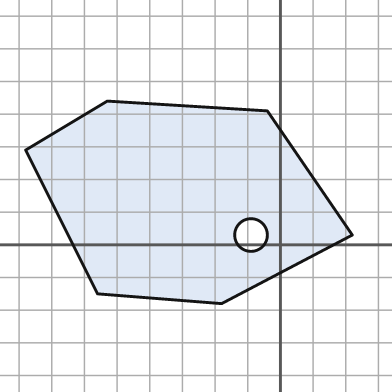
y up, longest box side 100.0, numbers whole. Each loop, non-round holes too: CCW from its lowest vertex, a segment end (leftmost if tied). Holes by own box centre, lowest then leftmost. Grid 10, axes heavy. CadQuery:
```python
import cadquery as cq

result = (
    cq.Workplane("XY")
    .moveTo(-18.0, -18.0)
    .lineTo(22.0, 3.0)
    .lineTo(-4.0, 41.0)
    .lineTo(-53.0, 44.0)
    .lineTo(-78.0, 29.0)
    .lineTo(-56.0, -15.0)
    .close()
    .moveTo(-9.0, 3.0)
    .circle(5.0)
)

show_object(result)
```